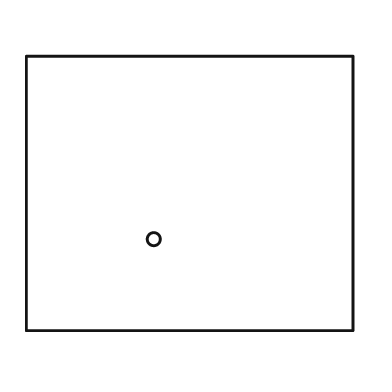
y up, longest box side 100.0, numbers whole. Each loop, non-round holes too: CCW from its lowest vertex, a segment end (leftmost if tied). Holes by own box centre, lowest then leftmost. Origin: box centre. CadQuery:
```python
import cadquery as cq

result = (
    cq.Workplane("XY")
    .moveTo(-50.0, -42.0)
    .lineTo(50.0, -42.0)
    .lineTo(50.0, 42.0)
    .lineTo(-50.0, 42.0)
    .close()
    .moveTo(-11.0, -14.0)
    .circle(2.0)
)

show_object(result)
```